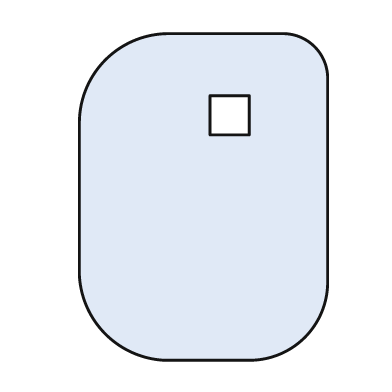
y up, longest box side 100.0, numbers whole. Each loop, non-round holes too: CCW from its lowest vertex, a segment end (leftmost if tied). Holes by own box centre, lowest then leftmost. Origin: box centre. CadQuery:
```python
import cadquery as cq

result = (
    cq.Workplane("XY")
    .moveTo(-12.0, -50.0)
    .lineTo(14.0, -50.0)
    .threePointArc((31.0, -43.0), (38.0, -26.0))
    .lineTo(38.0, 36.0)
    .threePointArc((34.0, 46.0), (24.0, 50.0))
    .lineTo(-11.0, 50.0)
    .threePointArc((-30.0, 42.0), (-38.0, 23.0))
    .lineTo(-38.0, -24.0)
    .threePointArc((-30.0, -42.0), (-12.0, -50.0))
    .close()
    .moveTo(2.0, 19.0)
    .lineTo(14.0, 19.0)
    .lineTo(14.0, 31.0)
    .lineTo(2.0, 31.0)
    .close()
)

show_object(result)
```